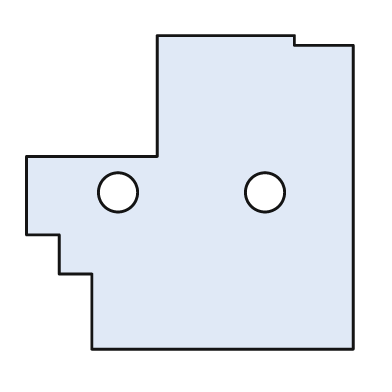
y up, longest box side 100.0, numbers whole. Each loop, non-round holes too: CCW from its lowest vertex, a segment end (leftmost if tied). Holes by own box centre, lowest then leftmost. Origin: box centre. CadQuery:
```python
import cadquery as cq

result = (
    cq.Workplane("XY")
    .moveTo(-30.0, -48.0)
    .lineTo(50.0, -48.0)
    .lineTo(50.0, 45.0)
    .lineTo(32.0, 45.0)
    .lineTo(32.0, 48.0)
    .lineTo(-10.0, 48.0)
    .lineTo(-10.0, 11.0)
    .lineTo(-50.0, 11.0)
    .lineTo(-50.0, -13.0)
    .lineTo(-40.0, -13.0)
    .lineTo(-40.0, -25.0)
    .lineTo(-30.0, -25.0)
    .close()
    .moveTo(-22.0, 0.0)
    .circle(6.0)
    .moveTo(23.0, 0.0)
    .circle(6.0)
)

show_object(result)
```